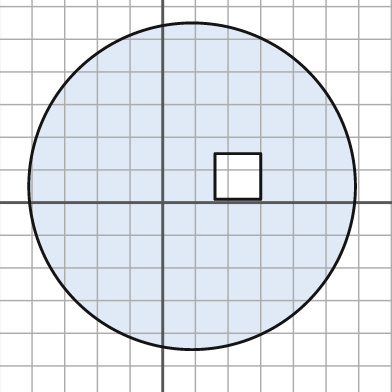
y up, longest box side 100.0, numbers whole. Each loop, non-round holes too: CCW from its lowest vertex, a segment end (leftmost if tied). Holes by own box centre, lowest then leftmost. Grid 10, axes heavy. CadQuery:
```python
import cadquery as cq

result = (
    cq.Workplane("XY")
    .moveTo(9.0, 5.0)
    .circle(50.0)
    .moveTo(16.0, 1.0)
    .lineTo(30.0, 1.0)
    .lineTo(30.0, 15.0)
    .lineTo(16.0, 15.0)
    .close()
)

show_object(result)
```